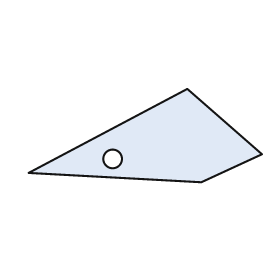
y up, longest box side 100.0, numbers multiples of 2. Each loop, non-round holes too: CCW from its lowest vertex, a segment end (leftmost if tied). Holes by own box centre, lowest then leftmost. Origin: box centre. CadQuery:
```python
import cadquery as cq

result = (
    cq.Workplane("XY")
    .moveTo(24.0, -20.0)
    .lineTo(50.0, -8.0)
    .lineTo(18.0, 20.0)
    .lineTo(-50.0, -16.0)
    .close()
    .moveTo(-14.0, -10.0)
    .circle(4.0)
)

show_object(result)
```